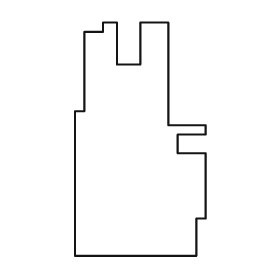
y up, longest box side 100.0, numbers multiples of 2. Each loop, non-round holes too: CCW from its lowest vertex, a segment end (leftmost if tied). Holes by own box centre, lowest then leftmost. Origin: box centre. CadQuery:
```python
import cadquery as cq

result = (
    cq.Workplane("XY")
    .moveTo(-28.0, -50.0)
    .lineTo(24.0, -50.0)
    .lineTo(24.0, -34.0)
    .lineTo(28.0, -34.0)
    .lineTo(28.0, -6.0)
    .lineTo(16.0, -6.0)
    .lineTo(16.0, 2.0)
    .lineTo(28.0, 2.0)
    .lineTo(28.0, 6.0)
    .lineTo(12.0, 6.0)
    .lineTo(12.0, 50.0)
    .lineTo(0.0, 50.0)
    .lineTo(0.0, 32.0)
    .lineTo(-10.0, 32.0)
    .lineTo(-10.0, 50.0)
    .lineTo(-16.0, 50.0)
    .lineTo(-16.0, 46.0)
    .lineTo(-24.0, 46.0)
    .lineTo(-24.0, 12.0)
    .lineTo(-28.0, 12.0)
    .close()
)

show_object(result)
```